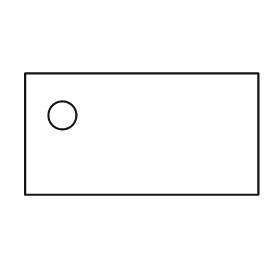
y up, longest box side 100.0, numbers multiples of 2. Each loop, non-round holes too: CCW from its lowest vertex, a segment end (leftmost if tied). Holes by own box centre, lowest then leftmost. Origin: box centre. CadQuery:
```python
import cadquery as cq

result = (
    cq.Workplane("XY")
    .moveTo(-50.0, -26.0)
    .lineTo(50.0, -26.0)
    .lineTo(50.0, 26.0)
    .lineTo(-50.0, 26.0)
    .close()
    .moveTo(-34.0, 8.0)
    .circle(6.0)
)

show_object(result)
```